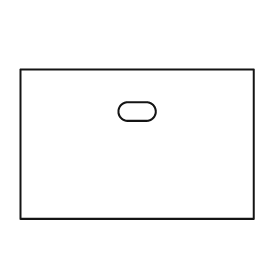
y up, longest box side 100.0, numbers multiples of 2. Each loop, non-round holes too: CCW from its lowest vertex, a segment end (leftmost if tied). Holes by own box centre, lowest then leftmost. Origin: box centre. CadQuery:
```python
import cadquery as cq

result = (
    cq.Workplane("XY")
    .moveTo(-50.0, -32.0)
    .lineTo(50.0, -32.0)
    .lineTo(50.0, 32.0)
    .lineTo(-50.0, 32.0)
    .close()
    .moveTo(-4.0, 10.0)
    .lineTo(4.0, 10.0)
    .threePointArc((8.0, 14.0), (4.0, 18.0))
    .lineTo(-4.0, 18.0)
    .threePointArc((-8.0, 14.0), (-4.0, 10.0))
    .close()
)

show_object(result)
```